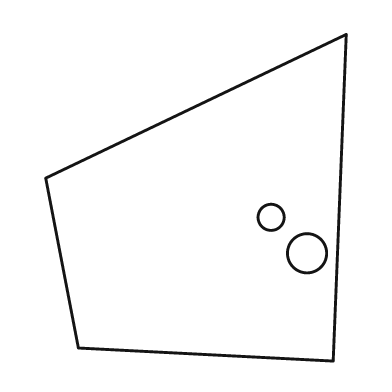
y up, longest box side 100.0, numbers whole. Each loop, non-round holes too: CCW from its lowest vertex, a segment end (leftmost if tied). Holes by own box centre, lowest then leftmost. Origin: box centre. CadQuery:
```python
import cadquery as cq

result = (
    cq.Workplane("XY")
    .moveTo(42.0, -50.0)
    .lineTo(46.0, 50.0)
    .lineTo(-46.0, 6.0)
    .lineTo(-36.0, -46.0)
    .close()
    .moveTo(34.0, -17.0)
    .circle(6.0)
    .moveTo(23.0, -6.0)
    .circle(4.0)
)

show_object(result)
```